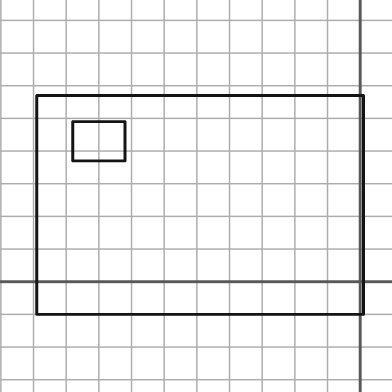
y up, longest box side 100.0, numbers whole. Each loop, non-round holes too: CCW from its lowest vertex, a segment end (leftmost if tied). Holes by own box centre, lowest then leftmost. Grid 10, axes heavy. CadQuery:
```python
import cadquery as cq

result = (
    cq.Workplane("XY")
    .moveTo(-99.0, -10.0)
    .lineTo(1.0, -10.0)
    .lineTo(1.0, 57.0)
    .lineTo(-99.0, 57.0)
    .close()
    .moveTo(-88.0, 37.0)
    .lineTo(-72.0, 37.0)
    .lineTo(-72.0, 49.0)
    .lineTo(-88.0, 49.0)
    .close()
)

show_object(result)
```